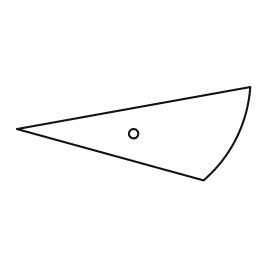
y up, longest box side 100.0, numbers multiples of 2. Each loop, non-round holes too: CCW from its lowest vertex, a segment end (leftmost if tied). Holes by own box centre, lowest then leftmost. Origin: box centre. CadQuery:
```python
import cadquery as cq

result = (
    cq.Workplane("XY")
    .moveTo(30.0, -20.0)
    .threePointArc((44.0, -2.0), (50.0, 20.0))
    .lineTo(-50.0, 2.0)
    .close()
    .moveTo(0.0, 0.0)
    .circle(2.0)
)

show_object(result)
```